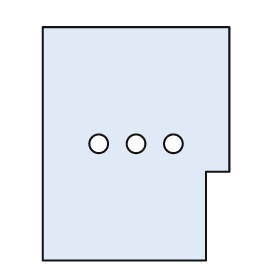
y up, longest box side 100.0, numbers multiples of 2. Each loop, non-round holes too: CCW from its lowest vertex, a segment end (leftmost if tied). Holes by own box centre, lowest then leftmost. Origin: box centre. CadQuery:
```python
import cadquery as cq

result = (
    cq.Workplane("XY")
    .moveTo(-40.0, -50.0)
    .lineTo(30.0, -50.0)
    .lineTo(30.0, -12.0)
    .lineTo(40.0, -12.0)
    .lineTo(40.0, 50.0)
    .lineTo(-40.0, 50.0)
    .close()
    .moveTo(-16.0, 0.0)
    .circle(4.0)
    .moveTo(0.0, 0.0)
    .circle(4.0)
    .moveTo(16.0, 0.0)
    .circle(4.0)
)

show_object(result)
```